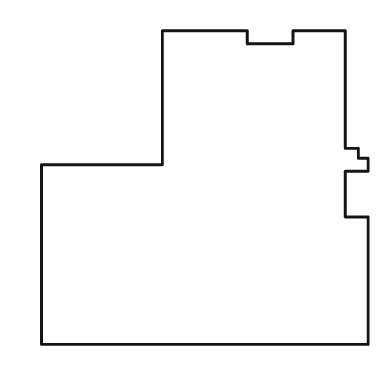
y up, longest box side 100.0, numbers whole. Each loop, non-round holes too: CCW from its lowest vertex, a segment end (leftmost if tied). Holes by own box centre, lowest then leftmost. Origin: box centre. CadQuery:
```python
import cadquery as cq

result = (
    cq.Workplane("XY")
    .moveTo(-50.0, -48.0)
    .lineTo(50.0, -48.0)
    .lineTo(50.0, -9.0)
    .lineTo(43.0, -9.0)
    .lineTo(43.0, 5.0)
    .lineTo(50.0, 5.0)
    .lineTo(50.0, 9.0)
    .lineTo(47.0, 9.0)
    .lineTo(47.0, 12.0)
    .lineTo(43.0, 12.0)
    .lineTo(43.0, 48.0)
    .lineTo(27.0, 48.0)
    .lineTo(27.0, 44.0)
    .lineTo(13.0, 44.0)
    .lineTo(13.0, 48.0)
    .lineTo(-13.0, 48.0)
    .lineTo(-13.0, 7.0)
    .lineTo(-50.0, 7.0)
    .close()
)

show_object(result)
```